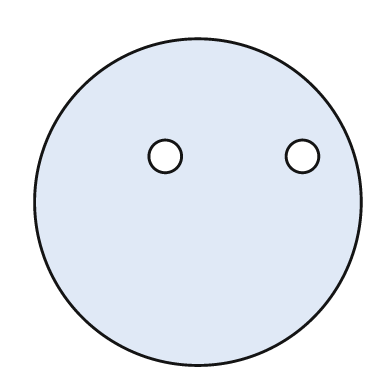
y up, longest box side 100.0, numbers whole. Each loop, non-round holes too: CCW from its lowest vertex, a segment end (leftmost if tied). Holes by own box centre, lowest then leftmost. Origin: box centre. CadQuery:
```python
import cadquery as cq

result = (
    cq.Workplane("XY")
    .moveTo(0.0, 0.0)
    .circle(50.0)
    .moveTo(-10.0, 14.0)
    .circle(5.0)
    .moveTo(32.0, 14.0)
    .circle(5.0)
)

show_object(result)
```